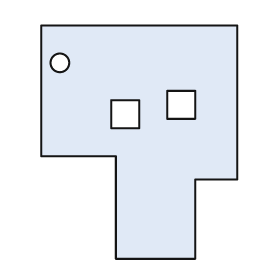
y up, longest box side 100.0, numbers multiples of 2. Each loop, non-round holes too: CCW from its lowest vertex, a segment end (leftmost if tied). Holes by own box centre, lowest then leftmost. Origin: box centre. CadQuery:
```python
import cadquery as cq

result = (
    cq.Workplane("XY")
    .moveTo(-10.0, -50.0)
    .lineTo(24.0, -50.0)
    .lineTo(24.0, -16.0)
    .lineTo(42.0, -16.0)
    .lineTo(42.0, 50.0)
    .lineTo(-42.0, 50.0)
    .lineTo(-42.0, -6.0)
    .lineTo(-10.0, -6.0)
    .close()
    .moveTo(-12.0, 6.0)
    .lineTo(0.0, 6.0)
    .lineTo(0.0, 18.0)
    .lineTo(-12.0, 18.0)
    .close()
    .moveTo(12.0, 10.0)
    .lineTo(24.0, 10.0)
    .lineTo(24.0, 22.0)
    .lineTo(12.0, 22.0)
    .close()
    .moveTo(-34.0, 34.0)
    .circle(4.0)
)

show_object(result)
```